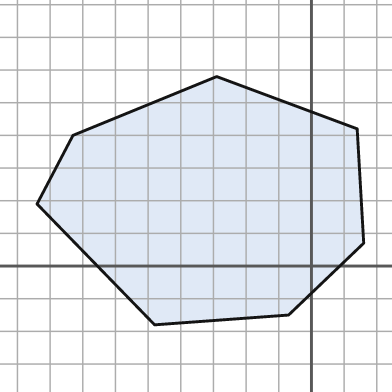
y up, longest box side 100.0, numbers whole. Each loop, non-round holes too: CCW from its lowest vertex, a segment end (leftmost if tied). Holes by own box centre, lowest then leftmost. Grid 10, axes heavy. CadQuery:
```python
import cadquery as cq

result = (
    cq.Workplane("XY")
    .moveTo(-48.0, -18.0)
    .lineTo(-7.0, -15.0)
    .lineTo(16.0, 7.0)
    .lineTo(14.0, 42.0)
    .lineTo(-29.0, 58.0)
    .lineTo(-73.0, 40.0)
    .lineTo(-84.0, 19.0)
    .close()
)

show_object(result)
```